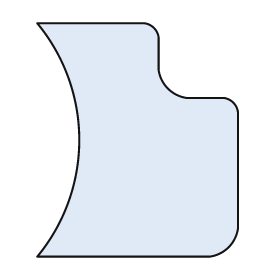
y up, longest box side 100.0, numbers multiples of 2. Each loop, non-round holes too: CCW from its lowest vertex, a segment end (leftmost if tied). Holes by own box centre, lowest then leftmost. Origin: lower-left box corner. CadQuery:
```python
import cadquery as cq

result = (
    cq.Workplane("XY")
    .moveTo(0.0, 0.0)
    .lineTo(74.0, 0.0)
    .threePointArc((82.0, 4.0), (86.0, 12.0))
    .lineTo(86.0, 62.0)
    .threePointArc((84.0, 66.0), (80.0, 68.0))
    .lineTo(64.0, 68.0)
    .threePointArc((56.0, 72.0), (52.0, 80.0))
    .lineTo(52.0, 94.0)
    .threePointArc((50.0, 98.0), (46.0, 100.0))
    .lineTo(0.0, 100.0)
    .threePointArc((18.0, 50.0), (0.0, 0.0))
    .close()
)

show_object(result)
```